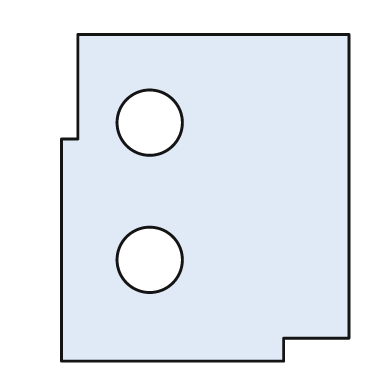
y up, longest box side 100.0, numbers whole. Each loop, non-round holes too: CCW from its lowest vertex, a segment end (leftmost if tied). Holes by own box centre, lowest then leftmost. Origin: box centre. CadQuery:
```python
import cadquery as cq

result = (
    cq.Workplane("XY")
    .moveTo(-44.0, -50.0)
    .lineTo(24.0, -50.0)
    .lineTo(24.0, -43.0)
    .lineTo(44.0, -43.0)
    .lineTo(44.0, 50.0)
    .lineTo(-39.0, 50.0)
    .lineTo(-39.0, 18.0)
    .lineTo(-44.0, 18.0)
    .close()
    .moveTo(-17.0, -19.0)
    .circle(10.0)
    .moveTo(-17.0, 23.0)
    .circle(10.0)
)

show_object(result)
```